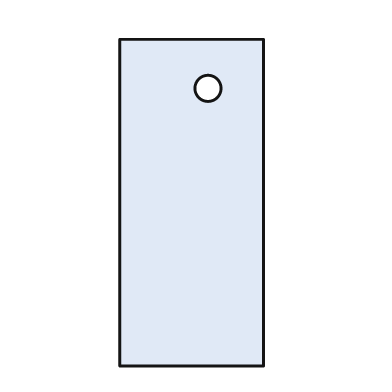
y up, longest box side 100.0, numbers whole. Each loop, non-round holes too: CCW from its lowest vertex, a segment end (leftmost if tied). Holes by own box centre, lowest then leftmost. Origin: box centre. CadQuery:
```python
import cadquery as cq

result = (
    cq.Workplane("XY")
    .moveTo(-22.0, -50.0)
    .lineTo(22.0, -50.0)
    .lineTo(22.0, 50.0)
    .lineTo(-22.0, 50.0)
    .close()
    .moveTo(5.0, 35.0)
    .circle(4.0)
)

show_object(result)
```